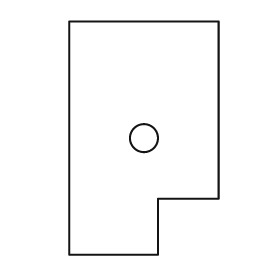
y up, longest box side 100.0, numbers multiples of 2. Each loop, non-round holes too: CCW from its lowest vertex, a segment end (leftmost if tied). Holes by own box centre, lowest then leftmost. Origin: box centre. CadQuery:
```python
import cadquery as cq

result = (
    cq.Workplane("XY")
    .moveTo(-32.0, -50.0)
    .lineTo(6.0, -50.0)
    .lineTo(6.0, -26.0)
    .lineTo(32.0, -26.0)
    .lineTo(32.0, 50.0)
    .lineTo(-32.0, 50.0)
    .close()
    .moveTo(0.0, 0.0)
    .circle(6.0)
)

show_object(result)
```